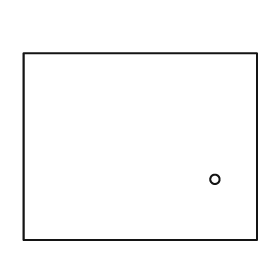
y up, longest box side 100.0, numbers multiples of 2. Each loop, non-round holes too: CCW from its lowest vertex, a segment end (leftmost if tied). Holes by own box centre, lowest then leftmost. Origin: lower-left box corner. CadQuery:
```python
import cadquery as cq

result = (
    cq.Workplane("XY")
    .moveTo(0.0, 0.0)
    .lineTo(100.0, 0.0)
    .lineTo(100.0, 80.0)
    .lineTo(0.0, 80.0)
    .close()
    .moveTo(82.0, 26.0)
    .circle(2.0)
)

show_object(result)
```